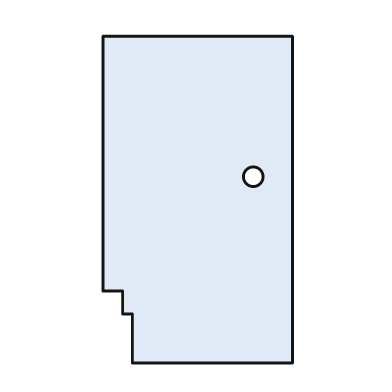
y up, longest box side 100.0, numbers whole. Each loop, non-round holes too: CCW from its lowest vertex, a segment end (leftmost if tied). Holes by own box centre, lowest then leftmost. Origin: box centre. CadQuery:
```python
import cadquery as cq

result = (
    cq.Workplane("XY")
    .moveTo(-20.0, -50.0)
    .lineTo(29.0, -50.0)
    .lineTo(29.0, 50.0)
    .lineTo(-29.0, 50.0)
    .lineTo(-29.0, -28.0)
    .lineTo(-23.0, -28.0)
    .lineTo(-23.0, -35.0)
    .lineTo(-20.0, -35.0)
    .close()
    .moveTo(17.0, 7.0)
    .circle(3.0)
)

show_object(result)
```